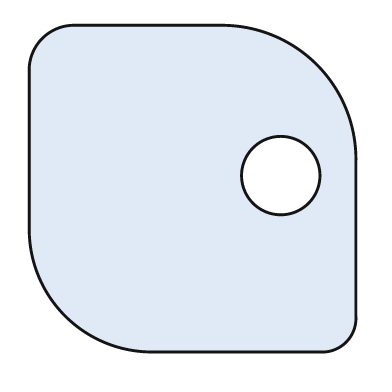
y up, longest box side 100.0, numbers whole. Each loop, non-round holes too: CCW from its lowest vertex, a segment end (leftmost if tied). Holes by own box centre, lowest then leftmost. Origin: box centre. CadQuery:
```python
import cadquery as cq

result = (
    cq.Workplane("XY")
    .moveTo(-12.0, -50.0)
    .lineTo(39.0, -50.0)
    .threePointArc((47.0, -47.0), (50.0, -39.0))
    .lineTo(50.0, 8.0)
    .threePointArc((38.0, 38.0), (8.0, 50.0))
    .lineTo(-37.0, 50.0)
    .threePointArc((-46.0, 46.0), (-50.0, 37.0))
    .lineTo(-50.0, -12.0)
    .threePointArc((-39.0, -39.0), (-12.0, -50.0))
    .close()
    .moveTo(27.0, 4.0)
    .circle(12.0)
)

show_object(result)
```